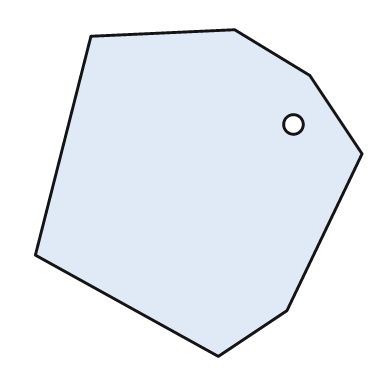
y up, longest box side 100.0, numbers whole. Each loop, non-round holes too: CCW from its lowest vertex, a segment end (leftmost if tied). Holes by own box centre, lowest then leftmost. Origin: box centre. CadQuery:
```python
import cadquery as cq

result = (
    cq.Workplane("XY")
    .moveTo(6.0, -50.0)
    .lineTo(27.0, -36.0)
    .lineTo(50.0, 12.0)
    .lineTo(34.0, 36.0)
    .lineTo(11.0, 50.0)
    .lineTo(-33.0, 48.0)
    .lineTo(-50.0, -19.0)
    .close()
    .moveTo(29.0, 21.0)
    .circle(3.0)
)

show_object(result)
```